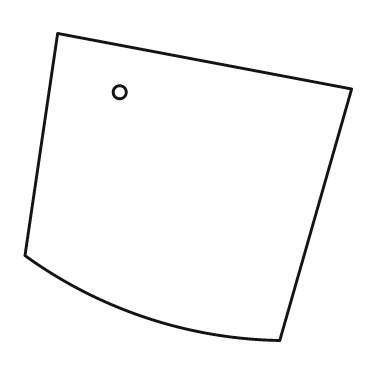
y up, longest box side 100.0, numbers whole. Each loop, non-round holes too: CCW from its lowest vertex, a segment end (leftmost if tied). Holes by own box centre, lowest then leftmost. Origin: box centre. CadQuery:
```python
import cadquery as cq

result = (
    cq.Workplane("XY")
    .moveTo(28.0, -47.0)
    .lineTo(50.0, 30.0)
    .lineTo(-40.0, 47.0)
    .lineTo(-50.0, -21.0)
    .threePointArc((-13.0, -40.0), (28.0, -47.0))
    .close()
    .moveTo(-21.0, 29.0)
    .circle(2.0)
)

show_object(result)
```